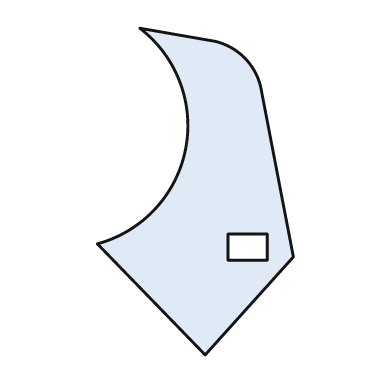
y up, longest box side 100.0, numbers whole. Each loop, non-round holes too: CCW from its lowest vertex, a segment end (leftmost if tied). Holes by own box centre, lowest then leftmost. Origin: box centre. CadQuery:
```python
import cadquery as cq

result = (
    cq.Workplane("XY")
    .moveTo(3.0, -50.0)
    .lineTo(30.0, -20.0)
    .lineTo(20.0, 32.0)
    .threePointArc((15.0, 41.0), (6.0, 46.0))
    .lineTo(-17.0, 50.0)
    .threePointArc((-3.0, 13.0), (-30.0, -16.0))
    .close()
    .moveTo(10.0, -21.0)
    .lineTo(22.0, -21.0)
    .lineTo(22.0, -13.0)
    .lineTo(10.0, -13.0)
    .close()
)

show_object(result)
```